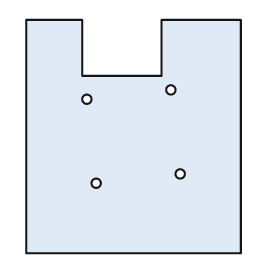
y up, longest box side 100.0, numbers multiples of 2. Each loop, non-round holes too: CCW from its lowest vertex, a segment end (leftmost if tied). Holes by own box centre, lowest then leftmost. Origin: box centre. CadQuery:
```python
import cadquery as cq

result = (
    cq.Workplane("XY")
    .moveTo(-46.0, -50.0)
    .lineTo(46.0, -50.0)
    .lineTo(46.0, 50.0)
    .lineTo(12.0, 50.0)
    .lineTo(12.0, 26.0)
    .lineTo(-22.0, 26.0)
    .lineTo(-22.0, 50.0)
    .lineTo(-46.0, 50.0)
    .close()
    .moveTo(-16.0, -20.0)
    .circle(2.0)
    .moveTo(20.0, -16.0)
    .circle(2.0)
    .moveTo(-20.0, 16.0)
    .circle(2.0)
    .moveTo(16.0, 20.0)
    .circle(2.0)
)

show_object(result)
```